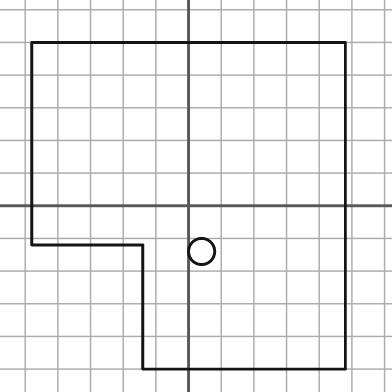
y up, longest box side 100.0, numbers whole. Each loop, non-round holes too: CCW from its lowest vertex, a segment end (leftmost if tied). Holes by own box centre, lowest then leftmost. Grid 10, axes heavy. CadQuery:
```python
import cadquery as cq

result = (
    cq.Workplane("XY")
    .moveTo(-14.0, -50.0)
    .lineTo(48.0, -50.0)
    .lineTo(48.0, 50.0)
    .lineTo(-48.0, 50.0)
    .lineTo(-48.0, -12.0)
    .lineTo(-14.0, -12.0)
    .close()
    .moveTo(4.0, -14.0)
    .circle(4.0)
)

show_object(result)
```